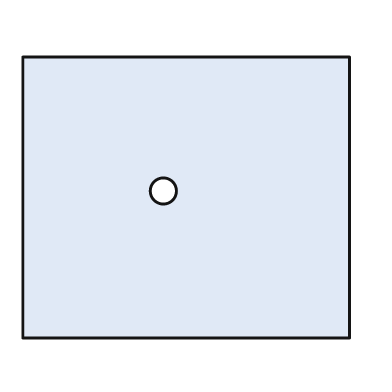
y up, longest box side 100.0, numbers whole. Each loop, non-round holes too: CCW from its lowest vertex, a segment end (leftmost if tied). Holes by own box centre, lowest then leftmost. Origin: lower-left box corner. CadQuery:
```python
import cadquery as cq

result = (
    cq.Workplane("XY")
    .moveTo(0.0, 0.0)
    .lineTo(100.0, 0.0)
    .lineTo(100.0, 86.0)
    .lineTo(0.0, 86.0)
    .close()
    .moveTo(43.0, 45.0)
    .circle(4.0)
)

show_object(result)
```